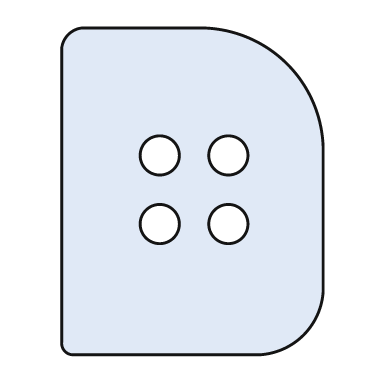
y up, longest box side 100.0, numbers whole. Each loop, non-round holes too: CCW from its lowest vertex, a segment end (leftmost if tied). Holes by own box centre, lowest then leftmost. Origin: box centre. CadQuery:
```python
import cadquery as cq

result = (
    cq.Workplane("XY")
    .moveTo(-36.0, -50.0)
    .lineTo(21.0, -50.0)
    .threePointArc((34.0, -44.0), (40.0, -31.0))
    .lineTo(40.0, 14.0)
    .threePointArc((29.0, 39.0), (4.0, 50.0))
    .lineTo(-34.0, 50.0)
    .threePointArc((-38.0, 48.0), (-40.0, 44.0))
    .lineTo(-40.0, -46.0)
    .threePointArc((-39.0, -49.0), (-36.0, -50.0))
    .close()
    .moveTo(-10.0, -10.0)
    .circle(6.0)
    .moveTo(11.0, -10.0)
    .circle(6.0)
    .moveTo(-10.0, 11.0)
    .circle(6.0)
    .moveTo(11.0, 11.0)
    .circle(6.0)
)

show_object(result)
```